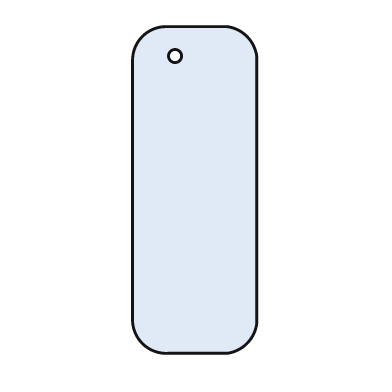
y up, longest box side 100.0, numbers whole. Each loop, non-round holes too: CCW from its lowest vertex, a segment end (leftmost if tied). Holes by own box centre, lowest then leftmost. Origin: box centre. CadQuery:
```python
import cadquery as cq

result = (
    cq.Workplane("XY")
    .moveTo(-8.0, -50.0)
    .lineTo(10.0, -50.0)
    .threePointArc((16.0, -47.0), (19.0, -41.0))
    .lineTo(19.0, 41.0)
    .threePointArc((16.0, 47.0), (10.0, 50.0))
    .lineTo(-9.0, 50.0)
    .threePointArc((-16.0, 47.0), (-19.0, 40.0))
    .lineTo(-19.0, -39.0)
    .threePointArc((-16.0, -47.0), (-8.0, -50.0))
    .close()
    .moveTo(-6.0, 41.0)
    .circle(2.0)
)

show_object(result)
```